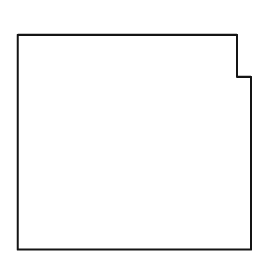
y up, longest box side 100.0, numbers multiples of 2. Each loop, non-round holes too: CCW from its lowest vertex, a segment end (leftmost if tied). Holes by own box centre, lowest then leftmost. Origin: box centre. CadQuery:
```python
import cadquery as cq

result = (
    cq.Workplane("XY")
    .moveTo(-50.0, -46.0)
    .lineTo(50.0, -46.0)
    .lineTo(50.0, 28.0)
    .lineTo(44.0, 28.0)
    .lineTo(44.0, 46.0)
    .lineTo(-50.0, 46.0)
    .close()
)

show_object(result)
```